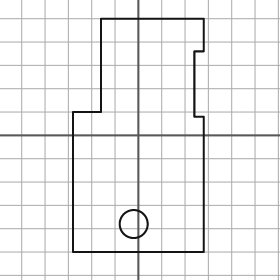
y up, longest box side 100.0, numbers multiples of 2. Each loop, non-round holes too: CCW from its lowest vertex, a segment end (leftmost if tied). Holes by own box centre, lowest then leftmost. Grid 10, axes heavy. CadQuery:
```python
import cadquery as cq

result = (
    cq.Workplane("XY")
    .moveTo(-28.0, -50.0)
    .lineTo(28.0, -50.0)
    .lineTo(28.0, 8.0)
    .lineTo(24.0, 8.0)
    .lineTo(24.0, 36.0)
    .lineTo(28.0, 36.0)
    .lineTo(28.0, 50.0)
    .lineTo(-16.0, 50.0)
    .lineTo(-16.0, 10.0)
    .lineTo(-28.0, 10.0)
    .close()
    .moveTo(-2.0, -38.0)
    .circle(6.0)
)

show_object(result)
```